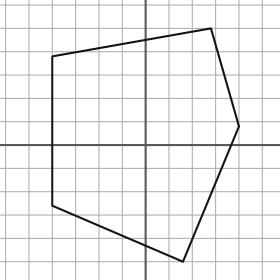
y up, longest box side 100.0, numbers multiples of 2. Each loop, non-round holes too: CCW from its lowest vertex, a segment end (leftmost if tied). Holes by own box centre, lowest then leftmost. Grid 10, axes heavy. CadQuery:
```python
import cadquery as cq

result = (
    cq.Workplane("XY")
    .moveTo(16.0, -50.0)
    .lineTo(40.0, 8.0)
    .lineTo(28.0, 50.0)
    .lineTo(-40.0, 38.0)
    .lineTo(-40.0, -26.0)
    .close()
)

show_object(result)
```